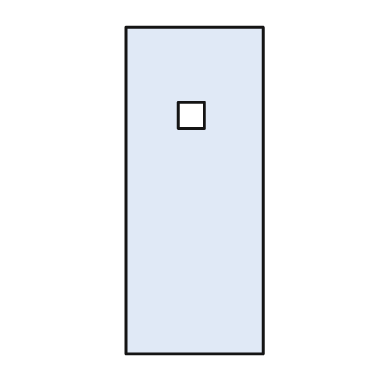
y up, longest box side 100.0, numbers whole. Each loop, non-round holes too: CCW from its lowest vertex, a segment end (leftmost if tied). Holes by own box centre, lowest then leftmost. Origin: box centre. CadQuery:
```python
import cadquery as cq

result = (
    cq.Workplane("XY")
    .moveTo(-21.0, -50.0)
    .lineTo(21.0, -50.0)
    .lineTo(21.0, 50.0)
    .lineTo(-21.0, 50.0)
    .close()
    .moveTo(-5.0, 19.0)
    .lineTo(3.0, 19.0)
    .lineTo(3.0, 27.0)
    .lineTo(-5.0, 27.0)
    .close()
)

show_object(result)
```